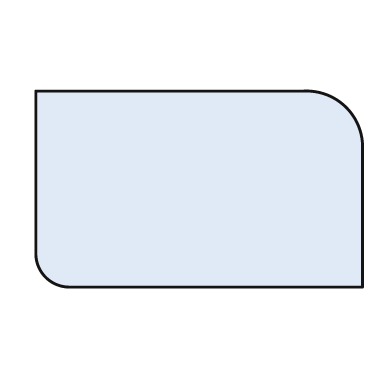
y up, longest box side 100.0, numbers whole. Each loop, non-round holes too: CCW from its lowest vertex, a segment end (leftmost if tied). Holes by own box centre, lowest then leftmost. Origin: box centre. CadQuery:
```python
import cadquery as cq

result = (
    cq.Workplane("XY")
    .moveTo(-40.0, -30.0)
    .lineTo(50.0, -30.0)
    .lineTo(50.0, 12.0)
    .threePointArc((45.0, 25.0), (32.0, 30.0))
    .lineTo(-50.0, 30.0)
    .lineTo(-50.0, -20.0)
    .threePointArc((-47.0, -27.0), (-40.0, -30.0))
    .close()
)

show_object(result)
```